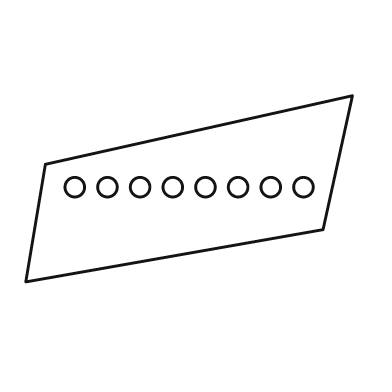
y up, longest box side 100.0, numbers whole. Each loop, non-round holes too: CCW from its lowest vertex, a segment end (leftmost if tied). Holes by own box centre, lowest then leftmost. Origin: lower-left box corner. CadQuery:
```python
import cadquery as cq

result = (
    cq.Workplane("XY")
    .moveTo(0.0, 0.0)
    .lineTo(91.0, 16.0)
    .lineTo(100.0, 57.0)
    .lineTo(6.0, 36.0)
    .close()
    .moveTo(15.0, 29.0)
    .circle(3.0)
    .moveTo(25.0, 29.0)
    .circle(3.0)
    .moveTo(35.0, 29.0)
    .circle(3.0)
    .moveTo(45.0, 29.0)
    .circle(3.0)
    .moveTo(55.0, 29.0)
    .circle(3.0)
    .moveTo(65.0, 29.0)
    .circle(3.0)
    .moveTo(75.0, 29.0)
    .circle(3.0)
    .moveTo(85.0, 29.0)
    .circle(3.0)
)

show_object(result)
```